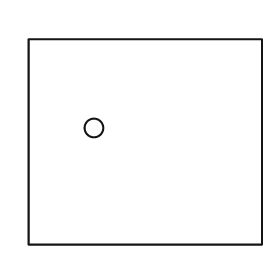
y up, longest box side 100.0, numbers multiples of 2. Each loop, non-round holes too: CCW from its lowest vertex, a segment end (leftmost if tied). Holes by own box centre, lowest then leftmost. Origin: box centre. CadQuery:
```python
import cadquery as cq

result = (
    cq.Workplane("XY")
    .moveTo(-50.0, -44.0)
    .lineTo(50.0, -44.0)
    .lineTo(50.0, 44.0)
    .lineTo(-50.0, 44.0)
    .close()
    .moveTo(-22.0, 6.0)
    .circle(4.0)
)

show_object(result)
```